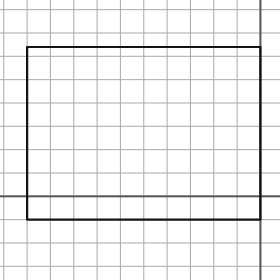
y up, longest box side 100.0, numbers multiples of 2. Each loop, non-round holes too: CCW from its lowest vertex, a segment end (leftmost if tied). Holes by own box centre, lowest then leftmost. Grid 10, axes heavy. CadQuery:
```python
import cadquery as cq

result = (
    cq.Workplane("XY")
    .moveTo(-100.0, -10.0)
    .lineTo(0.0, -10.0)
    .lineTo(0.0, 64.0)
    .lineTo(-100.0, 64.0)
    .close()
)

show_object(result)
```